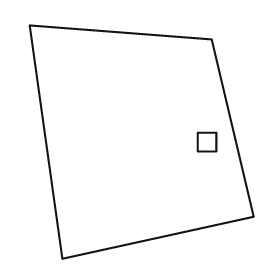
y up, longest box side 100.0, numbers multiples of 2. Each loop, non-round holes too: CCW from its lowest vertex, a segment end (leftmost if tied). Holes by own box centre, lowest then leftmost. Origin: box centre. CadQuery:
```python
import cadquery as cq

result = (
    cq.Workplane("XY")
    .moveTo(-34.0, -50.0)
    .lineTo(48.0, -32.0)
    .lineTo(30.0, 44.0)
    .lineTo(-48.0, 50.0)
    .close()
    .moveTo(24.0, -4.0)
    .lineTo(32.0, -4.0)
    .lineTo(32.0, 4.0)
    .lineTo(24.0, 4.0)
    .close()
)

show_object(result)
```